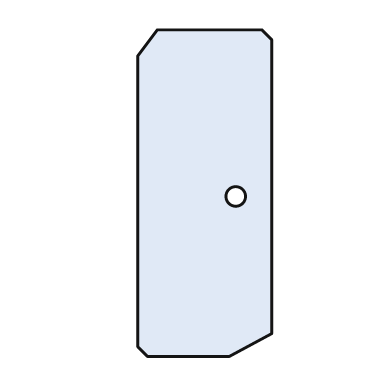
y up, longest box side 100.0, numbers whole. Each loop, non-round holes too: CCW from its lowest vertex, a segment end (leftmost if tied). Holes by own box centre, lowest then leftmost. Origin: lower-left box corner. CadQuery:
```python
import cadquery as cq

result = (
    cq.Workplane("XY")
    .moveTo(3.0, 0.0)
    .lineTo(28.0, 0.0)
    .lineTo(41.0, 7.0)
    .lineTo(41.0, 97.0)
    .lineTo(38.0, 100.0)
    .lineTo(6.0, 100.0)
    .lineTo(0.0, 92.0)
    .lineTo(0.0, 3.0)
    .close()
    .moveTo(30.0, 49.0)
    .circle(3.0)
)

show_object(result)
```